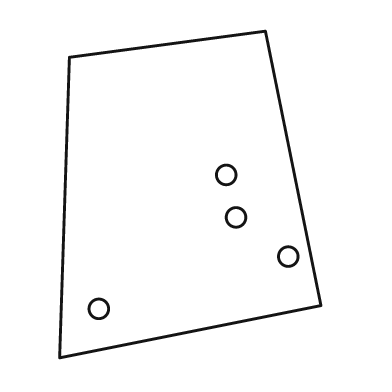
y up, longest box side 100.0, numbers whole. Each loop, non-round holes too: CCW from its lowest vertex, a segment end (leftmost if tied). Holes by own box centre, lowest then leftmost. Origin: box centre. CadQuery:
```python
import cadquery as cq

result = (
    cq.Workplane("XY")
    .moveTo(-40.0, -50.0)
    .lineTo(40.0, -34.0)
    .lineTo(23.0, 50.0)
    .lineTo(-37.0, 42.0)
    .close()
    .moveTo(-28.0, -35.0)
    .circle(3.0)
    .moveTo(30.0, -19.0)
    .circle(3.0)
    .moveTo(14.0, -7.0)
    .circle(3.0)
    .moveTo(11.0, 6.0)
    .circle(3.0)
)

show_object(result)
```